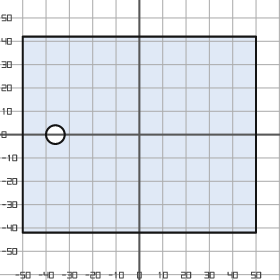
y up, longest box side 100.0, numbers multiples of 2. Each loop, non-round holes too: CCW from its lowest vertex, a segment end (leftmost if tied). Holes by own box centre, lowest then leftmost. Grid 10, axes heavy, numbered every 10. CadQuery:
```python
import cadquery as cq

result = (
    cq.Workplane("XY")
    .moveTo(-50.0, -42.0)
    .lineTo(50.0, -42.0)
    .lineTo(50.0, 42.0)
    .lineTo(-50.0, 42.0)
    .close()
    .moveTo(-36.0, 0.0)
    .circle(4.0)
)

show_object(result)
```